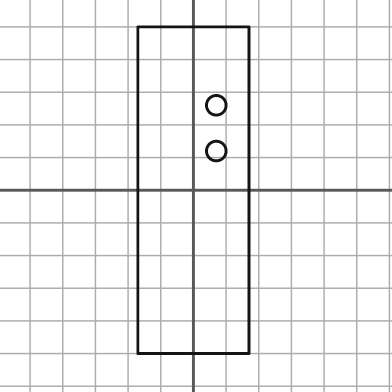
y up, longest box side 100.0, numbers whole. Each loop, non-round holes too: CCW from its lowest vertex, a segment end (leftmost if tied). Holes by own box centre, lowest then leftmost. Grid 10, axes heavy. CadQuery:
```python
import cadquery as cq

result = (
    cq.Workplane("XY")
    .moveTo(-17.0, -50.0)
    .lineTo(17.0, -50.0)
    .lineTo(17.0, 50.0)
    .lineTo(-17.0, 50.0)
    .close()
    .moveTo(7.0, 12.0)
    .circle(3.0)
    .moveTo(7.0, 26.0)
    .circle(3.0)
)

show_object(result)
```